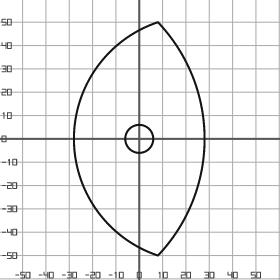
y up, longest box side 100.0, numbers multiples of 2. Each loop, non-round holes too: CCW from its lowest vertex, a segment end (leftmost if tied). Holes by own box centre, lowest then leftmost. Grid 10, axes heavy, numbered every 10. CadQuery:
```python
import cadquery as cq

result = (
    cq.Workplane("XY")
    .moveTo(8.0, -50.0)
    .threePointArc((28.0, 0.0), (8.0, 50.0))
    .threePointArc((-28.0, 0.0), (8.0, -50.0))
    .close()
    .moveTo(0.0, 0.0)
    .circle(6.0)
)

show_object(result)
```